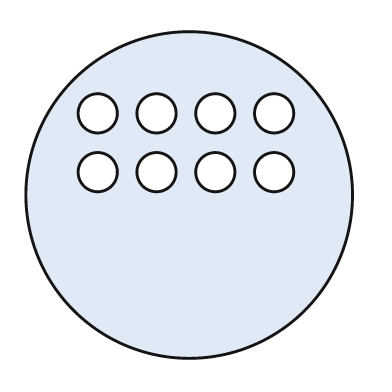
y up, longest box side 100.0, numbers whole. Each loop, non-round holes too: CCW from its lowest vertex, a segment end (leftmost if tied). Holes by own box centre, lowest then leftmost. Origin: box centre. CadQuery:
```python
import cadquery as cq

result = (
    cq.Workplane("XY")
    .moveTo(0.0, 0.0)
    .circle(50.0)
    .moveTo(-28.0, 7.0)
    .circle(6.0)
    .moveTo(-10.0, 7.0)
    .circle(6.0)
    .moveTo(8.0, 7.0)
    .circle(6.0)
    .moveTo(26.0, 7.0)
    .circle(6.0)
    .moveTo(-28.0, 25.0)
    .circle(6.0)
    .moveTo(-10.0, 25.0)
    .circle(6.0)
    .moveTo(8.0, 25.0)
    .circle(6.0)
    .moveTo(26.0, 25.0)
    .circle(6.0)
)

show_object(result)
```